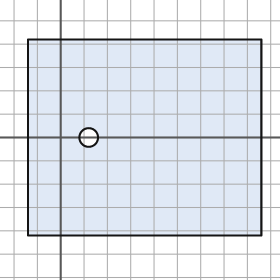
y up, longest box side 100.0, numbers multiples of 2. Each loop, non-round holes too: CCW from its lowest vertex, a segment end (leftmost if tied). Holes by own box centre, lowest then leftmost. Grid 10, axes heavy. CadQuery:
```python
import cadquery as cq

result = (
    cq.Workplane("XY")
    .moveTo(-14.0, -42.0)
    .lineTo(86.0, -42.0)
    .lineTo(86.0, 42.0)
    .lineTo(-14.0, 42.0)
    .close()
    .moveTo(12.0, 0.0)
    .circle(4.0)
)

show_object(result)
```